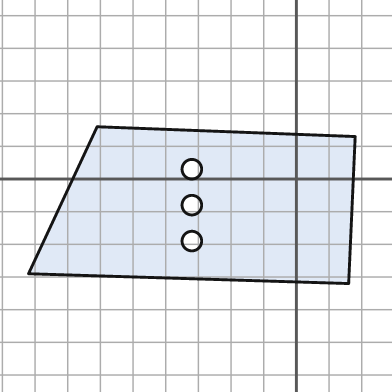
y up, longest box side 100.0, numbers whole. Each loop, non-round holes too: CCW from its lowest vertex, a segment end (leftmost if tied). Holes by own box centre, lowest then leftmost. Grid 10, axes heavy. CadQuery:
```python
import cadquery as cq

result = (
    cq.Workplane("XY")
    .moveTo(16.0, -32.0)
    .lineTo(18.0, 13.0)
    .lineTo(-61.0, 16.0)
    .lineTo(-82.0, -29.0)
    .close()
    .moveTo(-32.0, -19.0)
    .circle(3.0)
    .moveTo(-32.0, -8.0)
    .circle(3.0)
    .moveTo(-32.0, 3.0)
    .circle(3.0)
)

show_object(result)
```